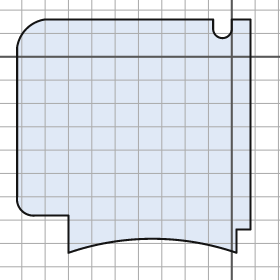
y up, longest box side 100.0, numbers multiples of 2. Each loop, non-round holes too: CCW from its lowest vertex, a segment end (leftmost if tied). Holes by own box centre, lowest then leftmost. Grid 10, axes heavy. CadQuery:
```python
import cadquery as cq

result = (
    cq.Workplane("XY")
    .moveTo(-70.0, -84.0)
    .threePointArc((-34.0, -78.0), (2.0, -84.0))
    .lineTo(2.0, -74.0)
    .lineTo(8.0, -74.0)
    .lineTo(8.0, 16.0)
    .lineTo(0.0, 16.0)
    .lineTo(0.0, 12.0)
    .threePointArc((-4.0, 8.0), (-8.0, 12.0))
    .lineTo(-8.0, 16.0)
    .lineTo(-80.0, 16.0)
    .threePointArc((-88.0, 12.0), (-92.0, 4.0))
    .lineTo(-92.0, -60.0)
    .threePointArc((-90.0, -66.0), (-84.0, -68.0))
    .lineTo(-70.0, -68.0)
    .close()
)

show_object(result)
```